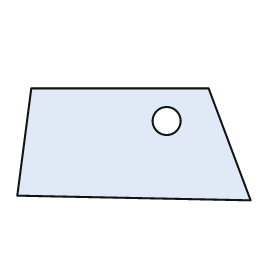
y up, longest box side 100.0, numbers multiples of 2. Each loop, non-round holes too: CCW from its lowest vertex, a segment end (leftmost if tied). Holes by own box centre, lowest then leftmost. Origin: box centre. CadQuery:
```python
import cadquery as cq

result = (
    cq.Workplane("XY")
    .moveTo(50.0, -24.0)
    .lineTo(32.0, 24.0)
    .lineTo(-44.0, 24.0)
    .lineTo(-50.0, -22.0)
    .close()
    .moveTo(14.0, 10.0)
    .circle(6.0)
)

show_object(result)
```